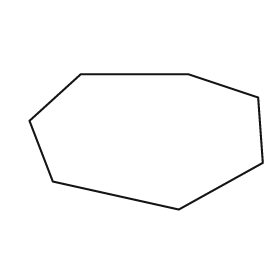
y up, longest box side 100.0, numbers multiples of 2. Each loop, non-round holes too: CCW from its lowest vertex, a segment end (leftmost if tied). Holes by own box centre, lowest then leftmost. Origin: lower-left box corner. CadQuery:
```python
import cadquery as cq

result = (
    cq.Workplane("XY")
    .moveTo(64.0, 0.0)
    .lineTo(100.0, 20.0)
    .lineTo(98.0, 48.0)
    .lineTo(68.0, 58.0)
    .lineTo(22.0, 58.0)
    .lineTo(0.0, 38.0)
    .lineTo(10.0, 12.0)
    .close()
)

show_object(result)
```